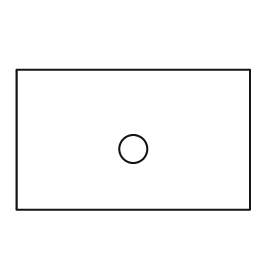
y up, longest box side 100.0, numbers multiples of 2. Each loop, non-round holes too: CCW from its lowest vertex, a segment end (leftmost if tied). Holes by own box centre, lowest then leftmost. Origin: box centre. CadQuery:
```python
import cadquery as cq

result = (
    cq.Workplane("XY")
    .moveTo(-50.0, -30.0)
    .lineTo(50.0, -30.0)
    .lineTo(50.0, 30.0)
    .lineTo(-50.0, 30.0)
    .close()
    .moveTo(0.0, -4.0)
    .circle(6.0)
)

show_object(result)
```